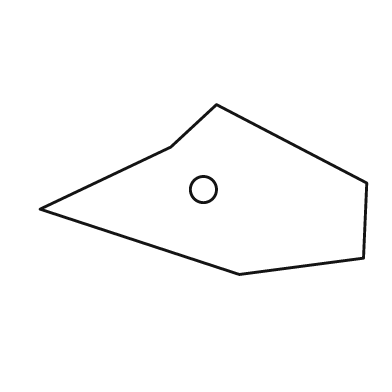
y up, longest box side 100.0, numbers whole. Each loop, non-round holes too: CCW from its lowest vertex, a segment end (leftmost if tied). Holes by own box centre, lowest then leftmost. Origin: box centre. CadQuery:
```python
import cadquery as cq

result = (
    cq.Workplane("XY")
    .moveTo(11.0, -26.0)
    .lineTo(49.0, -21.0)
    .lineTo(50.0, 2.0)
    .lineTo(4.0, 26.0)
    .lineTo(-10.0, 13.0)
    .lineTo(-50.0, -6.0)
    .close()
    .moveTo(0.0, 0.0)
    .circle(4.0)
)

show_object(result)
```